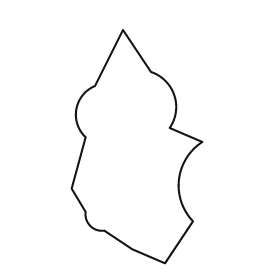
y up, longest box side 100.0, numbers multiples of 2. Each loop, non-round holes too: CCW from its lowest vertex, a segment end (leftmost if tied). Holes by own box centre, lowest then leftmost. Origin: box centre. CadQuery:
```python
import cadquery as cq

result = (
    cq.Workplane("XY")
    .moveTo(12.0, -50.0)
    .lineTo(24.0, -32.0)
    .threePointArc((18.0, -14.0), (28.0, 2.0))
    .lineTo(14.0, 8.0)
    .threePointArc((16.0, 22.0), (6.0, 32.0))
    .lineTo(-6.0, 50.0)
    .lineTo(-18.0, 26.0)
    .threePointArc((-26.0, 16.0), (-22.0, 4.0))
    .lineTo(-28.0, -18.0)
    .lineTo(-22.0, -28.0)
    .threePointArc((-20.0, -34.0), (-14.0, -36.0))
    .lineTo(-2.0, -44.0)
    .close()
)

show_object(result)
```